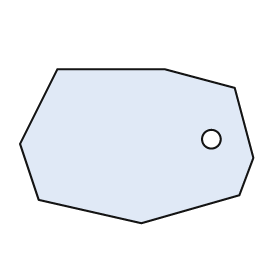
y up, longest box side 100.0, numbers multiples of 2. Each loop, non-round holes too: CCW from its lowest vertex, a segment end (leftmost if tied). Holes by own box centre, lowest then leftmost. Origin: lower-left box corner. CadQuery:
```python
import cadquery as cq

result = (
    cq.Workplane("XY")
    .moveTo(52.0, 0.0)
    .lineTo(94.0, 12.0)
    .lineTo(100.0, 28.0)
    .lineTo(92.0, 58.0)
    .lineTo(62.0, 66.0)
    .lineTo(16.0, 66.0)
    .lineTo(0.0, 34.0)
    .lineTo(8.0, 10.0)
    .close()
    .moveTo(82.0, 36.0)
    .circle(4.0)
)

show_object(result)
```